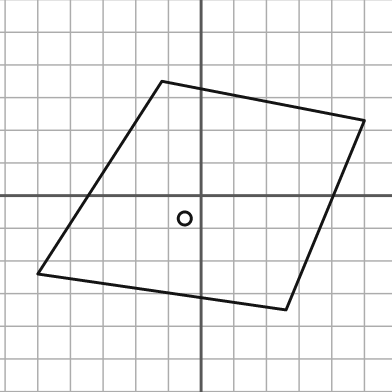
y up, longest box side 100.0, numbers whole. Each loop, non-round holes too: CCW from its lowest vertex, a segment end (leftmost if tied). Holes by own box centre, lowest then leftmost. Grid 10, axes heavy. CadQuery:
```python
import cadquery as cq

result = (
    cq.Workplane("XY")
    .moveTo(26.0, -35.0)
    .lineTo(50.0, 23.0)
    .lineTo(-12.0, 35.0)
    .lineTo(-50.0, -24.0)
    .close()
    .moveTo(-5.0, -7.0)
    .circle(2.0)
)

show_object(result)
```